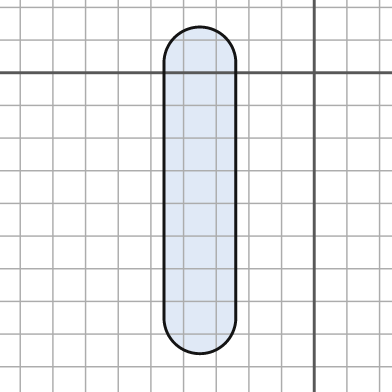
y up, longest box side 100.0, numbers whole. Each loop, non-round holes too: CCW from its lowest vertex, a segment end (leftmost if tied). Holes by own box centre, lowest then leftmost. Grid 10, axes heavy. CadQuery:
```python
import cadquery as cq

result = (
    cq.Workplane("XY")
    .moveTo(-46.0, -75.0)
    .threePointArc((-35.0, -86.0), (-24.0, -75.0))
    .lineTo(-24.0, 3.0)
    .threePointArc((-35.0, 14.0), (-46.0, 3.0))
    .close()
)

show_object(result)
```